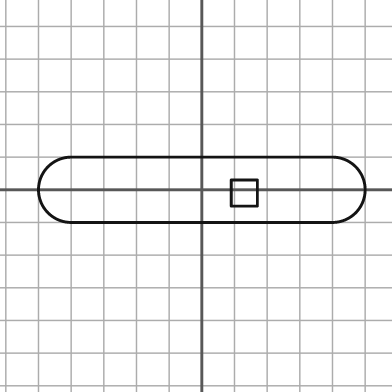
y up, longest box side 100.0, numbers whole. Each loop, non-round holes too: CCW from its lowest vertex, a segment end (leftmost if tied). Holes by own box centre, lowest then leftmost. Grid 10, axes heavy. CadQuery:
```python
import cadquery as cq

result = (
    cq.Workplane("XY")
    .moveTo(-40.0, -10.0)
    .lineTo(40.0, -10.0)
    .threePointArc((50.0, 0.0), (40.0, 10.0))
    .lineTo(-40.0, 10.0)
    .threePointArc((-50.0, 0.0), (-40.0, -10.0))
    .close()
    .moveTo(9.0, -5.0)
    .lineTo(17.0, -5.0)
    .lineTo(17.0, 3.0)
    .lineTo(9.0, 3.0)
    .close()
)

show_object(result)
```